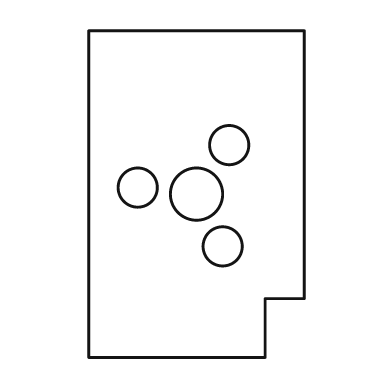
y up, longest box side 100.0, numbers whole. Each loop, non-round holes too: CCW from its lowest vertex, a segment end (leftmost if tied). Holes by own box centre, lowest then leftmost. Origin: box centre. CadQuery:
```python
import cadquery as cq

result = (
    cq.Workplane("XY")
    .moveTo(-33.0, -50.0)
    .lineTo(21.0, -50.0)
    .lineTo(21.0, -32.0)
    .lineTo(33.0, -32.0)
    .lineTo(33.0, 50.0)
    .lineTo(-33.0, 50.0)
    .close()
    .moveTo(8.0, -16.0)
    .circle(6.0)
    .moveTo(0.0, 0.0)
    .circle(8.0)
    .moveTo(-18.0, 2.0)
    .circle(6.0)
    .moveTo(10.0, 15.0)
    .circle(6.0)
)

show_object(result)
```